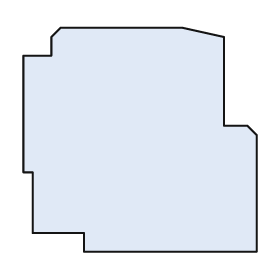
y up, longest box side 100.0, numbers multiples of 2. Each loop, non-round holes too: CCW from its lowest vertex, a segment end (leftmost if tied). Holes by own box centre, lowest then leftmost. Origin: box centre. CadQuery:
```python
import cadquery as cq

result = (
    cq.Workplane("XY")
    .moveTo(-24.0, -48.0)
    .lineTo(50.0, -48.0)
    .lineTo(50.0, 2.0)
    .lineTo(46.0, 6.0)
    .lineTo(36.0, 6.0)
    .lineTo(36.0, 44.0)
    .lineTo(18.0, 48.0)
    .lineTo(-34.0, 48.0)
    .lineTo(-38.0, 44.0)
    .lineTo(-38.0, 36.0)
    .lineTo(-50.0, 36.0)
    .lineTo(-50.0, -14.0)
    .lineTo(-46.0, -14.0)
    .lineTo(-46.0, -40.0)
    .lineTo(-24.0, -40.0)
    .close()
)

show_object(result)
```